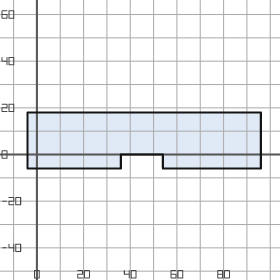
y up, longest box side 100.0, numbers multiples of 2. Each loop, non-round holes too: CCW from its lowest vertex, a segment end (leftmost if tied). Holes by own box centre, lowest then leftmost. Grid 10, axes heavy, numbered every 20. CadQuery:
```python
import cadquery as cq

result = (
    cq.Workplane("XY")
    .moveTo(-4.0, -6.0)
    .lineTo(36.0, -6.0)
    .lineTo(36.0, 0.0)
    .lineTo(54.0, 0.0)
    .lineTo(54.0, -6.0)
    .lineTo(96.0, -6.0)
    .lineTo(96.0, 18.0)
    .lineTo(-4.0, 18.0)
    .close()
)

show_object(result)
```